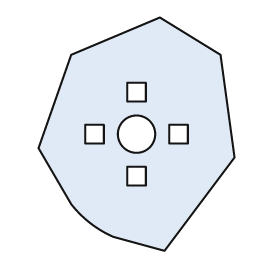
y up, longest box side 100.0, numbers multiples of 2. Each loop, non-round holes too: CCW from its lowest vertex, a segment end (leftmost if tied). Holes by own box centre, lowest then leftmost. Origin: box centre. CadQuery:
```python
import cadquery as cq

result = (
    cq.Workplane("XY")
    .moveTo(12.0, -50.0)
    .lineTo(42.0, -10.0)
    .lineTo(36.0, 34.0)
    .lineTo(10.0, 50.0)
    .lineTo(-28.0, 34.0)
    .lineTo(-42.0, -6.0)
    .lineTo(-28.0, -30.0)
    .threePointArc((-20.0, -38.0), (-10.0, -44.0))
    .close()
    .moveTo(-4.0, -22.0)
    .lineTo(4.0, -22.0)
    .lineTo(4.0, -14.0)
    .lineTo(-4.0, -14.0)
    .close()
    .moveTo(-22.0, -4.0)
    .lineTo(-14.0, -4.0)
    .lineTo(-14.0, 4.0)
    .lineTo(-22.0, 4.0)
    .close()
    .moveTo(0.0, 0.0)
    .circle(8.0)
    .moveTo(14.0, -4.0)
    .lineTo(22.0, -4.0)
    .lineTo(22.0, 4.0)
    .lineTo(14.0, 4.0)
    .close()
    .moveTo(-4.0, 14.0)
    .lineTo(4.0, 14.0)
    .lineTo(4.0, 22.0)
    .lineTo(-4.0, 22.0)
    .close()
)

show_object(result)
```